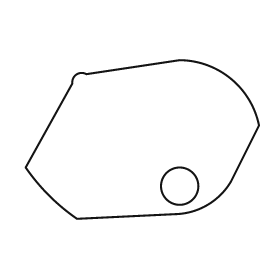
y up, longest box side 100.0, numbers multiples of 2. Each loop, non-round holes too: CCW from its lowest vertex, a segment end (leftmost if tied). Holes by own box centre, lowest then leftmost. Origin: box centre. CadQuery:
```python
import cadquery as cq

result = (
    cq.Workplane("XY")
    .moveTo(-28.0, -34.0)
    .lineTo(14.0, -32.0)
    .threePointArc((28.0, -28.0), (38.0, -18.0))
    .lineTo(50.0, 6.0)
    .threePointArc((38.0, 26.0), (16.0, 34.0))
    .lineTo(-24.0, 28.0)
    .threePointArc((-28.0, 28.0), (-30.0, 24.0))
    .lineTo(-50.0, -12.0)
    .threePointArc((-40.0, -24.0), (-28.0, -34.0))
    .close()
    .moveTo(16.0, -20.0)
    .circle(8.0)
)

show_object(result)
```